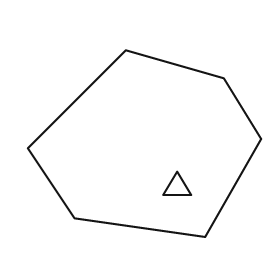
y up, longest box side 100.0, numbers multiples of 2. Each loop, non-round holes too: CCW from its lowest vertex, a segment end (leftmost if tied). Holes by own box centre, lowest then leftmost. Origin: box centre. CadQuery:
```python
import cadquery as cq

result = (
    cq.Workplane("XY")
    .moveTo(26.0, -40.0)
    .lineTo(50.0, 2.0)
    .lineTo(34.0, 28.0)
    .lineTo(-8.0, 40.0)
    .lineTo(-50.0, -2.0)
    .lineTo(-30.0, -32.0)
    .close()
    .moveTo(8.0, -22.0)
    .lineTo(20.0, -22.0)
    .lineTo(14.0, -12.0)
    .close()
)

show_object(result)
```